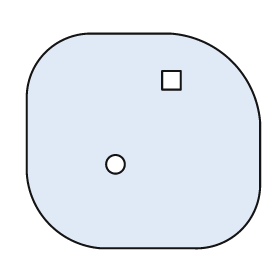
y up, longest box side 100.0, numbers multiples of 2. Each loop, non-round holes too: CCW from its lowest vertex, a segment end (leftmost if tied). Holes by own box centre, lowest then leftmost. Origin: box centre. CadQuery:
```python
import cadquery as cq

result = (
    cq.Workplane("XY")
    .moveTo(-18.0, -46.0)
    .lineTo(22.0, -46.0)
    .threePointArc((42.0, -38.0), (50.0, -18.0))
    .lineTo(50.0, 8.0)
    .threePointArc((38.0, 34.0), (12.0, 46.0))
    .lineTo(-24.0, 46.0)
    .threePointArc((-42.0, 38.0), (-50.0, 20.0))
    .lineTo(-50.0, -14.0)
    .threePointArc((-40.0, -36.0), (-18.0, -46.0))
    .close()
    .moveTo(-12.0, -10.0)
    .circle(4.0)
    .moveTo(8.0, 22.0)
    .lineTo(16.0, 22.0)
    .lineTo(16.0, 30.0)
    .lineTo(8.0, 30.0)
    .close()
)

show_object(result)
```